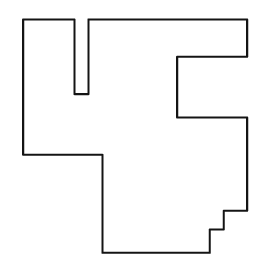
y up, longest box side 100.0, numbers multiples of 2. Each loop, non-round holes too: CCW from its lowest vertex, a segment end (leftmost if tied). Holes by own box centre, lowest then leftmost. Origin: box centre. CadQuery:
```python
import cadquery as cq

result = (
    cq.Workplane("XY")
    .moveTo(-14.0, -50.0)
    .lineTo(32.0, -50.0)
    .lineTo(32.0, -40.0)
    .lineTo(38.0, -40.0)
    .lineTo(38.0, -32.0)
    .lineTo(48.0, -32.0)
    .lineTo(48.0, 8.0)
    .lineTo(18.0, 8.0)
    .lineTo(18.0, 34.0)
    .lineTo(48.0, 34.0)
    .lineTo(48.0, 50.0)
    .lineTo(-20.0, 50.0)
    .lineTo(-20.0, 18.0)
    .lineTo(-26.0, 18.0)
    .lineTo(-26.0, 50.0)
    .lineTo(-48.0, 50.0)
    .lineTo(-48.0, -8.0)
    .lineTo(-14.0, -8.0)
    .close()
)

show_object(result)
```